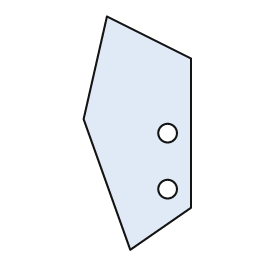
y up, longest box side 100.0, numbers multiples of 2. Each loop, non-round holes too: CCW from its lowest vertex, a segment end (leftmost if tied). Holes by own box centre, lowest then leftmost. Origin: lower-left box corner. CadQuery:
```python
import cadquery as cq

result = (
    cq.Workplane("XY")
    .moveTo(20.0, 0.0)
    .lineTo(46.0, 18.0)
    .lineTo(46.0, 82.0)
    .lineTo(10.0, 100.0)
    .lineTo(0.0, 56.0)
    .close()
    .moveTo(36.0, 26.0)
    .circle(4.0)
    .moveTo(36.0, 50.0)
    .circle(4.0)
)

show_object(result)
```